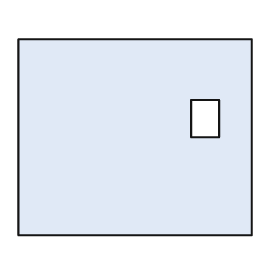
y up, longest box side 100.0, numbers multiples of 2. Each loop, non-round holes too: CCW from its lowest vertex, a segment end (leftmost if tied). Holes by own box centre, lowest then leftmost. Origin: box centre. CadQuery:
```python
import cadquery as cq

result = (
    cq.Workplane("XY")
    .moveTo(-50.0, -42.0)
    .lineTo(50.0, -42.0)
    .lineTo(50.0, 42.0)
    .lineTo(-50.0, 42.0)
    .close()
    .moveTo(24.0, 0.0)
    .lineTo(36.0, 0.0)
    .lineTo(36.0, 16.0)
    .lineTo(24.0, 16.0)
    .close()
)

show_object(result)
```